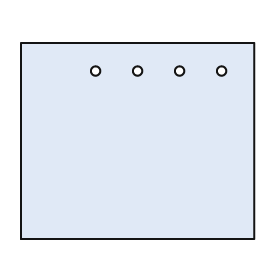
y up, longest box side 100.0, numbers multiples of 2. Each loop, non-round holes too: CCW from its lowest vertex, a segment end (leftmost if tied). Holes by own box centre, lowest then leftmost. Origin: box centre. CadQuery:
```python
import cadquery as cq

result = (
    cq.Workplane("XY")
    .moveTo(-50.0, -42.0)
    .lineTo(50.0, -42.0)
    .lineTo(50.0, 42.0)
    .lineTo(-50.0, 42.0)
    .close()
    .moveTo(-18.0, 30.0)
    .circle(2.0)
    .moveTo(0.0, 30.0)
    .circle(2.0)
    .moveTo(18.0, 30.0)
    .circle(2.0)
    .moveTo(36.0, 30.0)
    .circle(2.0)
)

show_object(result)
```